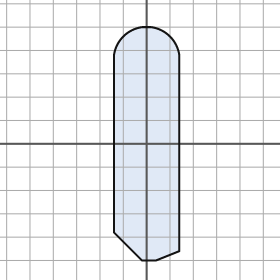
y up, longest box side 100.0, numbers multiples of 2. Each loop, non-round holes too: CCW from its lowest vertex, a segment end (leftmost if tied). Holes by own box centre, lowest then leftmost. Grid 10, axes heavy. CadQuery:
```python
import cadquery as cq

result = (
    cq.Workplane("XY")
    .moveTo(-2.0, -50.0)
    .lineTo(4.0, -50.0)
    .lineTo(14.0, -46.0)
    .lineTo(14.0, 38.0)
    .threePointArc((10.0, 46.0), (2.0, 50.0))
    .lineTo(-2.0, 50.0)
    .threePointArc((-10.0, 46.0), (-14.0, 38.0))
    .lineTo(-14.0, -38.0)
    .close()
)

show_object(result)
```